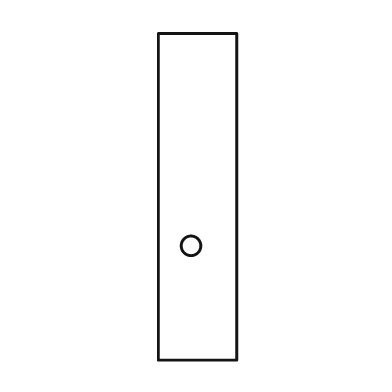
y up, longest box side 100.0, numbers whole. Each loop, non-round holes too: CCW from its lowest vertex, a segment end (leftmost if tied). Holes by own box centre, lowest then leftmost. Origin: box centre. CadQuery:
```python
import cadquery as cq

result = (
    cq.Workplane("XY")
    .moveTo(-12.0, -50.0)
    .lineTo(12.0, -50.0)
    .lineTo(12.0, 50.0)
    .lineTo(-12.0, 50.0)
    .close()
    .moveTo(-2.0, -15.0)
    .circle(3.0)
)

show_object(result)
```